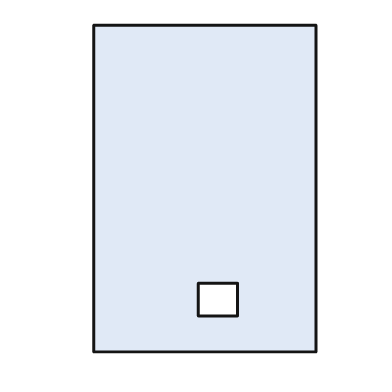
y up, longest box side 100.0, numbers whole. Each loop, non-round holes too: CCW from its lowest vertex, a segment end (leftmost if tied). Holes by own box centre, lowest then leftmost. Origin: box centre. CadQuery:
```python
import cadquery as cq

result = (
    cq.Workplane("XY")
    .moveTo(-34.0, -50.0)
    .lineTo(34.0, -50.0)
    .lineTo(34.0, 50.0)
    .lineTo(-34.0, 50.0)
    .close()
    .moveTo(-2.0, -39.0)
    .lineTo(10.0, -39.0)
    .lineTo(10.0, -29.0)
    .lineTo(-2.0, -29.0)
    .close()
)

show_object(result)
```